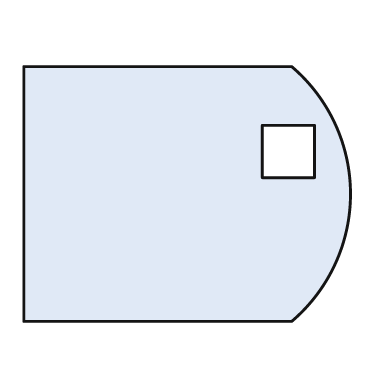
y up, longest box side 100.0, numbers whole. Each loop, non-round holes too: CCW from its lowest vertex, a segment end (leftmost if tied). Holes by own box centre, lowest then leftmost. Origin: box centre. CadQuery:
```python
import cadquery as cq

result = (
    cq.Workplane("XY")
    .moveTo(-50.0, -39.0)
    .lineTo(32.0, -39.0)
    .threePointArc((50.0, 0.0), (32.0, 39.0))
    .lineTo(-50.0, 39.0)
    .close()
    .moveTo(23.0, 5.0)
    .lineTo(39.0, 5.0)
    .lineTo(39.0, 21.0)
    .lineTo(23.0, 21.0)
    .close()
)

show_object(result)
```